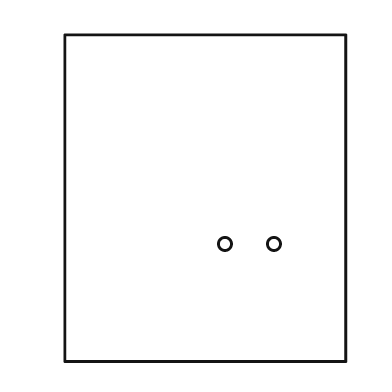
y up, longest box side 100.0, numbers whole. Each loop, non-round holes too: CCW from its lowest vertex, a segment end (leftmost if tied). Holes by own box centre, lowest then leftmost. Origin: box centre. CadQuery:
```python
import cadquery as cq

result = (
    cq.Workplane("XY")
    .moveTo(-43.0, -50.0)
    .lineTo(43.0, -50.0)
    .lineTo(43.0, 50.0)
    .lineTo(-43.0, 50.0)
    .close()
    .moveTo(6.0, -14.0)
    .circle(2.0)
    .moveTo(21.0, -14.0)
    .circle(2.0)
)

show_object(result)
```